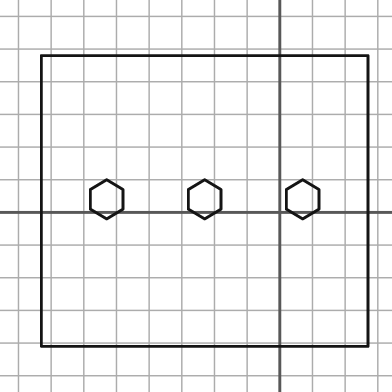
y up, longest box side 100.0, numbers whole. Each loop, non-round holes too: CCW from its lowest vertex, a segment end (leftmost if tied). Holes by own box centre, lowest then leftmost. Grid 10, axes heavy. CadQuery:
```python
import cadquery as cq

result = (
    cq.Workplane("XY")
    .moveTo(-73.0, -41.0)
    .lineTo(27.0, -41.0)
    .lineTo(27.0, 48.0)
    .lineTo(-73.0, 48.0)
    .close()
    .moveTo(-53.0, -2.0)
    .lineTo(-48.0, 1.0)
    .lineTo(-48.0, 7.0)
    .lineTo(-53.0, 10.0)
    .lineTo(-58.0, 7.0)
    .lineTo(-58.0, 1.0)
    .close()
    .moveTo(-23.0, -2.0)
    .lineTo(-18.0, 1.0)
    .lineTo(-18.0, 7.0)
    .lineTo(-23.0, 10.0)
    .lineTo(-28.0, 7.0)
    .lineTo(-28.0, 1.0)
    .close()
    .moveTo(7.0, -2.0)
    .lineTo(12.0, 1.0)
    .lineTo(12.0, 7.0)
    .lineTo(7.0, 10.0)
    .lineTo(2.0, 7.0)
    .lineTo(2.0, 1.0)
    .close()
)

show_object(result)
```